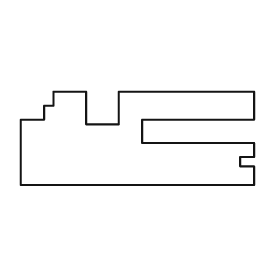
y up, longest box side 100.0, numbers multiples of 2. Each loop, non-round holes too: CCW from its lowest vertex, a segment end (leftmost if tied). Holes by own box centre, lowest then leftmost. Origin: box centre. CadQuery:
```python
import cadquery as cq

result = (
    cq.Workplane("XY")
    .moveTo(-50.0, -20.0)
    .lineTo(50.0, -20.0)
    .lineTo(50.0, -12.0)
    .lineTo(44.0, -12.0)
    .lineTo(44.0, -8.0)
    .lineTo(50.0, -8.0)
    .lineTo(50.0, -2.0)
    .lineTo(2.0, -2.0)
    .lineTo(2.0, 8.0)
    .lineTo(50.0, 8.0)
    .lineTo(50.0, 20.0)
    .lineTo(-8.0, 20.0)
    .lineTo(-8.0, 6.0)
    .lineTo(-22.0, 6.0)
    .lineTo(-22.0, 20.0)
    .lineTo(-36.0, 20.0)
    .lineTo(-36.0, 14.0)
    .lineTo(-40.0, 14.0)
    .lineTo(-40.0, 8.0)
    .lineTo(-50.0, 8.0)
    .close()
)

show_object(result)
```